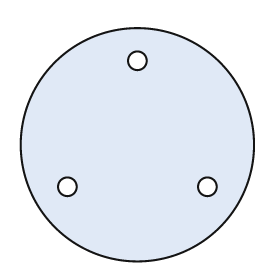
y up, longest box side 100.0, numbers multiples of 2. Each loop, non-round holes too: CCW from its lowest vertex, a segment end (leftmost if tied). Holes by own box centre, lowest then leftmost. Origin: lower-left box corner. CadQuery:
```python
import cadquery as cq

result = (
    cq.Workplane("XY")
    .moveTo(50.0, 50.0)
    .circle(50.0)
    .moveTo(20.0, 32.0)
    .circle(4.0)
    .moveTo(80.0, 32.0)
    .circle(4.0)
    .moveTo(50.0, 86.0)
    .circle(4.0)
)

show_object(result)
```